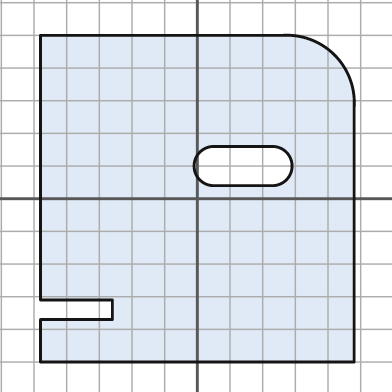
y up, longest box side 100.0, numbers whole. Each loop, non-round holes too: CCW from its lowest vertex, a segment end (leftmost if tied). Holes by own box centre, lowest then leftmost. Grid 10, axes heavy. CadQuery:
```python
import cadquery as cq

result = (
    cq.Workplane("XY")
    .moveTo(-48.0, -50.0)
    .lineTo(48.0, -50.0)
    .lineTo(48.0, 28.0)
    .threePointArc((42.0, 44.0), (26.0, 50.0))
    .lineTo(-48.0, 50.0)
    .lineTo(-48.0, -31.0)
    .lineTo(-26.0, -31.0)
    .lineTo(-26.0, -37.0)
    .lineTo(-48.0, -37.0)
    .close()
    .moveTo(5.0, 4.0)
    .lineTo(23.0, 4.0)
    .threePointArc((29.0, 10.0), (23.0, 16.0))
    .lineTo(5.0, 16.0)
    .threePointArc((-1.0, 10.0), (5.0, 4.0))
    .close()
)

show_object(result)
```